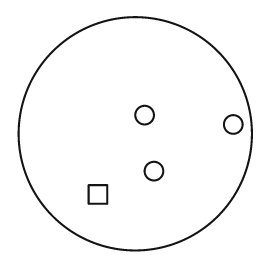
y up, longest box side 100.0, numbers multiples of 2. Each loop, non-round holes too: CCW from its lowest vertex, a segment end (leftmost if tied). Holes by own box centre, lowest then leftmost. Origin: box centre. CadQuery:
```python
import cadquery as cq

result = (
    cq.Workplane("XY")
    .moveTo(0.0, 0.0)
    .circle(50.0)
    .moveTo(-20.0, -30.0)
    .lineTo(-12.0, -30.0)
    .lineTo(-12.0, -22.0)
    .lineTo(-20.0, -22.0)
    .close()
    .moveTo(8.0, -16.0)
    .circle(4.0)
    .moveTo(42.0, 4.0)
    .circle(4.0)
    .moveTo(4.0, 8.0)
    .circle(4.0)
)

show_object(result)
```